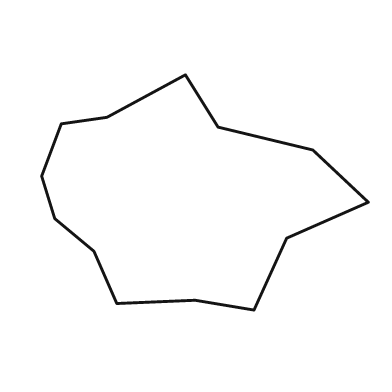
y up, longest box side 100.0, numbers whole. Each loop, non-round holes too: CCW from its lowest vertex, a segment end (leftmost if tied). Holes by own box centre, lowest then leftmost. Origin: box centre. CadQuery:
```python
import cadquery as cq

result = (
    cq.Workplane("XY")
    .moveTo(15.0, -36.0)
    .lineTo(25.0, -14.0)
    .lineTo(50.0, -3.0)
    .lineTo(33.0, 13.0)
    .lineTo(4.0, 20.0)
    .lineTo(-6.0, 36.0)
    .lineTo(-30.0, 23.0)
    .lineTo(-44.0, 21.0)
    .lineTo(-50.0, 5.0)
    .lineTo(-46.0, -8.0)
    .lineTo(-34.0, -18.0)
    .lineTo(-27.0, -34.0)
    .lineTo(-3.0, -33.0)
    .close()
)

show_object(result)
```